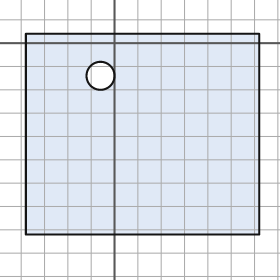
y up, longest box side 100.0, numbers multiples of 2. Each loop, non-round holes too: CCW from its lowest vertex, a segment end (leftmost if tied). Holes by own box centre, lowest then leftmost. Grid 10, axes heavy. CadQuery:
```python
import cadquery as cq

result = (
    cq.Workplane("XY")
    .moveTo(-38.0, -82.0)
    .lineTo(62.0, -82.0)
    .lineTo(62.0, 4.0)
    .lineTo(-38.0, 4.0)
    .close()
    .moveTo(-6.0, -14.0)
    .circle(6.0)
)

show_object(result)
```